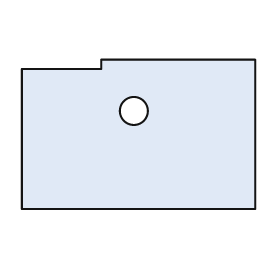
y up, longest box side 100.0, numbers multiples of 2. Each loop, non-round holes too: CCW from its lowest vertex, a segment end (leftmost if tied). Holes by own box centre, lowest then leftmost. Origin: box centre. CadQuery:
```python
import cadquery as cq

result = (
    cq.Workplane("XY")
    .moveTo(-50.0, -32.0)
    .lineTo(50.0, -32.0)
    .lineTo(50.0, 32.0)
    .lineTo(-16.0, 32.0)
    .lineTo(-16.0, 28.0)
    .lineTo(-50.0, 28.0)
    .close()
    .moveTo(-2.0, 10.0)
    .circle(6.0)
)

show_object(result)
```